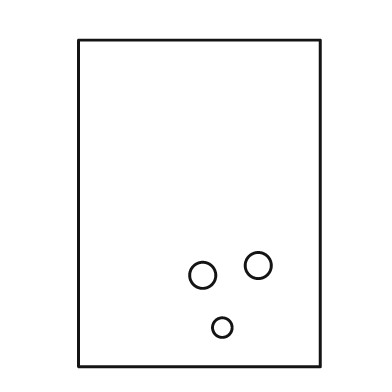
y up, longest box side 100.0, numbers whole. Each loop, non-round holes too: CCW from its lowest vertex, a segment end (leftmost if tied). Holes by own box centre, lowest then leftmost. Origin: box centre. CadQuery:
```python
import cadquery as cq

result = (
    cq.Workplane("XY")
    .moveTo(-37.0, -50.0)
    .lineTo(37.0, -50.0)
    .lineTo(37.0, 50.0)
    .lineTo(-37.0, 50.0)
    .close()
    .moveTo(7.0, -38.0)
    .circle(3.0)
    .moveTo(1.0, -22.0)
    .circle(4.0)
    .moveTo(18.0, -19.0)
    .circle(4.0)
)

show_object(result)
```